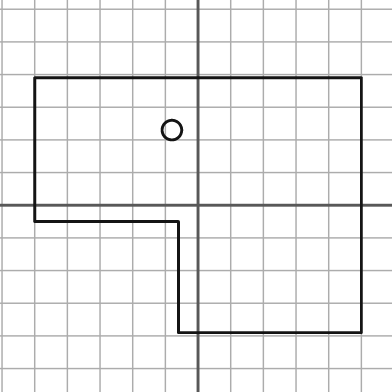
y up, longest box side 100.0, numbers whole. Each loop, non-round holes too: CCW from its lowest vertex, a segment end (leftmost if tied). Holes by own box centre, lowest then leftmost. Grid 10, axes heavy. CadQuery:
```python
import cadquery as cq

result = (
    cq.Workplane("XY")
    .moveTo(-6.0, -39.0)
    .lineTo(50.0, -39.0)
    .lineTo(50.0, 39.0)
    .lineTo(-50.0, 39.0)
    .lineTo(-50.0, -5.0)
    .lineTo(-6.0, -5.0)
    .close()
    .moveTo(-8.0, 23.0)
    .circle(3.0)
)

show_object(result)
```